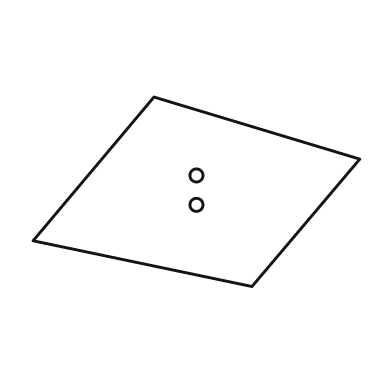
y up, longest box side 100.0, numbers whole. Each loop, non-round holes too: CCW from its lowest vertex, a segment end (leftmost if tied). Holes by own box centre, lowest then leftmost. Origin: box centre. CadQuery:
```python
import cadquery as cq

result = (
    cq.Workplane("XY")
    .moveTo(17.0, -29.0)
    .lineTo(50.0, 10.0)
    .lineTo(-13.0, 29.0)
    .lineTo(-50.0, -15.0)
    .close()
    .moveTo(0.0, -4.0)
    .circle(2.0)
    .moveTo(0.0, 5.0)
    .circle(2.0)
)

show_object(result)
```